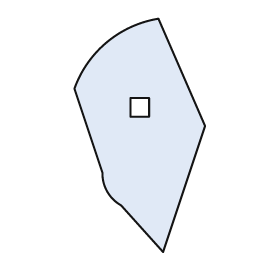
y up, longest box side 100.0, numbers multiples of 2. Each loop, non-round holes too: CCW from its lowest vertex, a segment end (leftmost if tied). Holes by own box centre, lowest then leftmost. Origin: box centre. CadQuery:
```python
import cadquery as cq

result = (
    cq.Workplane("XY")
    .moveTo(10.0, -50.0)
    .lineTo(28.0, 4.0)
    .lineTo(8.0, 50.0)
    .threePointArc((-14.0, 40.0), (-28.0, 20.0))
    .lineTo(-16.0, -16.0)
    .threePointArc((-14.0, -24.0), (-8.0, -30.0))
    .close()
    .moveTo(-4.0, 8.0)
    .lineTo(4.0, 8.0)
    .lineTo(4.0, 16.0)
    .lineTo(-4.0, 16.0)
    .close()
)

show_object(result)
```